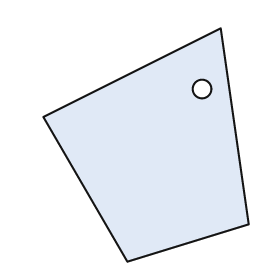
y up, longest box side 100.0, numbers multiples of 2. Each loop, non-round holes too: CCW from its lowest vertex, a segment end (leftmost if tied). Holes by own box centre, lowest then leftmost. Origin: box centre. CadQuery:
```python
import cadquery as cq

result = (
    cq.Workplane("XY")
    .moveTo(-8.0, -50.0)
    .lineTo(44.0, -34.0)
    .lineTo(32.0, 50.0)
    .lineTo(-44.0, 12.0)
    .close()
    .moveTo(24.0, 24.0)
    .circle(4.0)
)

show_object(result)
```